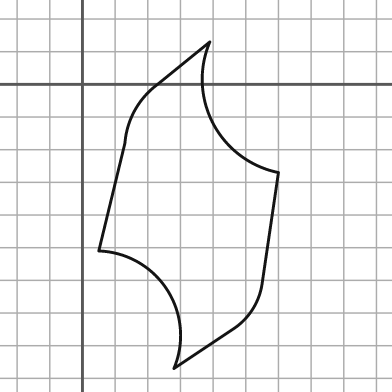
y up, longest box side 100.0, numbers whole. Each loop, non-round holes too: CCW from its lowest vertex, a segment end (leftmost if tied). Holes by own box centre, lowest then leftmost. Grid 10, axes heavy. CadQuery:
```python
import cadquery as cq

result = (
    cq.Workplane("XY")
    .moveTo(28.0, -87.0)
    .lineTo(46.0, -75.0)
    .threePointArc((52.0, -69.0), (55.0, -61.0))
    .lineTo(60.0, -27.0)
    .threePointArc((40.0, -12.0), (39.0, 13.0))
    .lineTo(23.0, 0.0)
    .threePointArc((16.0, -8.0), (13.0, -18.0))
    .lineTo(5.0, -51.0)
    .threePointArc((26.0, -63.0), (28.0, -87.0))
    .close()
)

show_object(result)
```